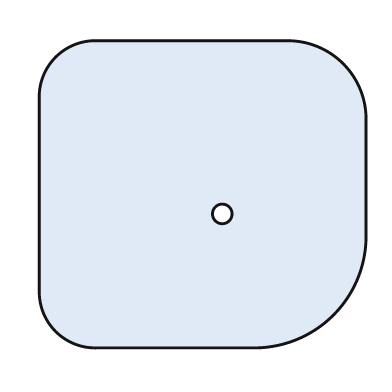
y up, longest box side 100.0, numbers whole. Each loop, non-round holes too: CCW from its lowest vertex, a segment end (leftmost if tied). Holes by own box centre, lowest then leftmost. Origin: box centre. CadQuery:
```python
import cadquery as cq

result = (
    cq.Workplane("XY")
    .moveTo(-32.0, -47.0)
    .lineTo(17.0, -47.0)
    .threePointArc((40.0, -37.0), (50.0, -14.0))
    .lineTo(50.0, 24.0)
    .threePointArc((43.0, 40.0), (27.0, 47.0))
    .lineTo(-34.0, 47.0)
    .threePointArc((-45.0, 42.0), (-50.0, 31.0))
    .lineTo(-50.0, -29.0)
    .threePointArc((-45.0, -42.0), (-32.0, -47.0))
    .close()
    .moveTo(6.0, -6.0)
    .circle(3.0)
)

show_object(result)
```